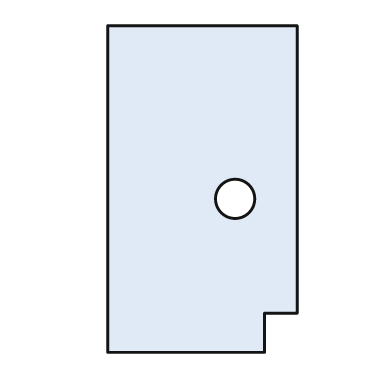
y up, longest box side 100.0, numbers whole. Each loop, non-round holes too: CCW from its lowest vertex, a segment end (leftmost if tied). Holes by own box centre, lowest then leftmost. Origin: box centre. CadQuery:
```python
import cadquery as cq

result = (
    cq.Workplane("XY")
    .moveTo(-29.0, -50.0)
    .lineTo(19.0, -50.0)
    .lineTo(19.0, -38.0)
    .lineTo(29.0, -38.0)
    .lineTo(29.0, 50.0)
    .lineTo(-29.0, 50.0)
    .close()
    .moveTo(10.0, -3.0)
    .circle(6.0)
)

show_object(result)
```